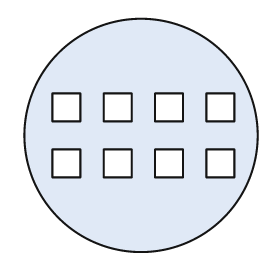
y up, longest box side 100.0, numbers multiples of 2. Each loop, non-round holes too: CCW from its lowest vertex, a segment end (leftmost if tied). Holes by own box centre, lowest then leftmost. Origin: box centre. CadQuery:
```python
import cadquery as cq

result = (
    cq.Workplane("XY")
    .moveTo(0.0, 0.0)
    .circle(50.0)
    .moveTo(-38.0, -18.0)
    .lineTo(-26.0, -18.0)
    .lineTo(-26.0, -6.0)
    .lineTo(-38.0, -6.0)
    .close()
    .moveTo(-16.0, -18.0)
    .lineTo(-4.0, -18.0)
    .lineTo(-4.0, -6.0)
    .lineTo(-16.0, -6.0)
    .close()
    .moveTo(6.0, -18.0)
    .lineTo(18.0, -18.0)
    .lineTo(18.0, -6.0)
    .lineTo(6.0, -6.0)
    .close()
    .moveTo(28.0, -18.0)
    .lineTo(40.0, -18.0)
    .lineTo(40.0, -6.0)
    .lineTo(28.0, -6.0)
    .close()
    .moveTo(-38.0, 6.0)
    .lineTo(-26.0, 6.0)
    .lineTo(-26.0, 18.0)
    .lineTo(-38.0, 18.0)
    .close()
    .moveTo(-16.0, 6.0)
    .lineTo(-4.0, 6.0)
    .lineTo(-4.0, 18.0)
    .lineTo(-16.0, 18.0)
    .close()
    .moveTo(6.0, 6.0)
    .lineTo(18.0, 6.0)
    .lineTo(18.0, 18.0)
    .lineTo(6.0, 18.0)
    .close()
    .moveTo(28.0, 6.0)
    .lineTo(40.0, 6.0)
    .lineTo(40.0, 18.0)
    .lineTo(28.0, 18.0)
    .close()
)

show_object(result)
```